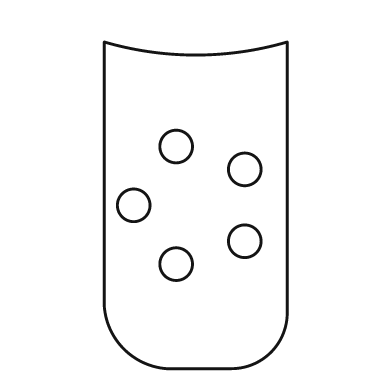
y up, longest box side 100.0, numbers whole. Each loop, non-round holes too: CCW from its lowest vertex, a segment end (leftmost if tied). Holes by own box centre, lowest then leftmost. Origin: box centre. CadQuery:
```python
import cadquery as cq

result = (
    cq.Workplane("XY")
    .moveTo(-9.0, -50.0)
    .lineTo(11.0, -50.0)
    .threePointArc((23.0, -45.0), (28.0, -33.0))
    .lineTo(28.0, 50.0)
    .threePointArc((0.0, 46.0), (-28.0, 50.0))
    .lineTo(-28.0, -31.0)
    .threePointArc((-22.0, -44.0), (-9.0, -50.0))
    .close()
    .moveTo(-6.0, -18.0)
    .circle(5.0)
    .moveTo(15.0, -11.0)
    .circle(5.0)
    .moveTo(-19.0, 0.0)
    .circle(5.0)
    .moveTo(15.0, 11.0)
    .circle(5.0)
    .moveTo(-6.0, 18.0)
    .circle(5.0)
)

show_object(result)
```